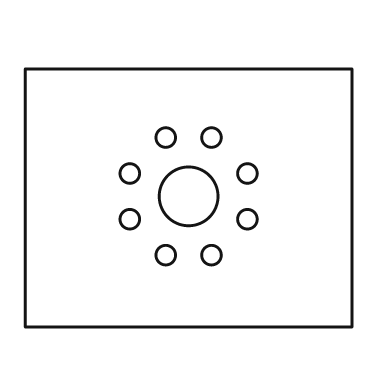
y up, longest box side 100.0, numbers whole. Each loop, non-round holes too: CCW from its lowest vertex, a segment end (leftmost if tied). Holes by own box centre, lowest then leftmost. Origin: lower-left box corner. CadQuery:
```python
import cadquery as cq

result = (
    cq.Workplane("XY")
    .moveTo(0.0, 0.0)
    .lineTo(100.0, 0.0)
    .lineTo(100.0, 79.0)
    .lineTo(0.0, 79.0)
    .close()
    .moveTo(43.0, 22.0)
    .circle(3.0)
    .moveTo(57.0, 22.0)
    .circle(3.0)
    .moveTo(32.0, 33.0)
    .circle(3.0)
    .moveTo(68.0, 33.0)
    .circle(3.0)
    .moveTo(50.0, 40.0)
    .circle(9.0)
    .moveTo(32.0, 47.0)
    .circle(3.0)
    .moveTo(68.0, 47.0)
    .circle(3.0)
    .moveTo(43.0, 58.0)
    .circle(3.0)
    .moveTo(57.0, 58.0)
    .circle(3.0)
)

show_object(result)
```